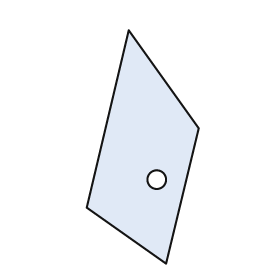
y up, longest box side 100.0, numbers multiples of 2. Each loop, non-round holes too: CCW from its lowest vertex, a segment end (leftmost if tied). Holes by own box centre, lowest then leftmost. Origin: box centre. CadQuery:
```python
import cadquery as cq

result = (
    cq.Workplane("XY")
    .moveTo(10.0, -50.0)
    .lineTo(24.0, 8.0)
    .lineTo(-6.0, 50.0)
    .lineTo(-24.0, -26.0)
    .close()
    .moveTo(6.0, -14.0)
    .circle(4.0)
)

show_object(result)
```